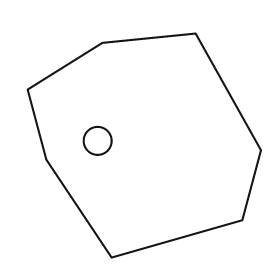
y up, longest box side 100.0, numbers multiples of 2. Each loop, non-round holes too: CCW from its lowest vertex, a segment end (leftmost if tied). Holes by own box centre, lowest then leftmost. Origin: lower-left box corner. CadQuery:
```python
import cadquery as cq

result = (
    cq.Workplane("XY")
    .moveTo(36.0, 0.0)
    .lineTo(92.0, 16.0)
    .lineTo(100.0, 46.0)
    .lineTo(72.0, 96.0)
    .lineTo(32.0, 92.0)
    .lineTo(0.0, 72.0)
    .lineTo(8.0, 42.0)
    .close()
    .moveTo(30.0, 50.0)
    .circle(6.0)
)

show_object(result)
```